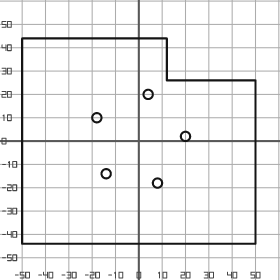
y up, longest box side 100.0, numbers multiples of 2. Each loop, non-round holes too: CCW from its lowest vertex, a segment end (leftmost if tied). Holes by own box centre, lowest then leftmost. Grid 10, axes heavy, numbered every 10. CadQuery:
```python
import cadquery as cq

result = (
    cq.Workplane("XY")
    .moveTo(-50.0, -44.0)
    .lineTo(50.0, -44.0)
    .lineTo(50.0, 26.0)
    .lineTo(12.0, 26.0)
    .lineTo(12.0, 44.0)
    .lineTo(-50.0, 44.0)
    .close()
    .moveTo(8.0, -18.0)
    .circle(2.0)
    .moveTo(-14.0, -14.0)
    .circle(2.0)
    .moveTo(20.0, 2.0)
    .circle(2.0)
    .moveTo(-18.0, 10.0)
    .circle(2.0)
    .moveTo(4.0, 20.0)
    .circle(2.0)
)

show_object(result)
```